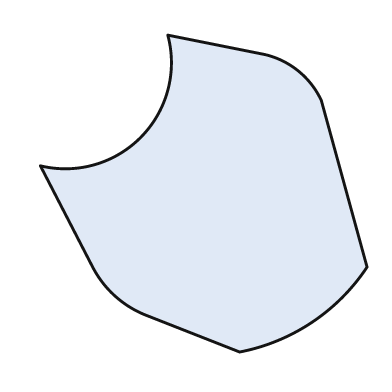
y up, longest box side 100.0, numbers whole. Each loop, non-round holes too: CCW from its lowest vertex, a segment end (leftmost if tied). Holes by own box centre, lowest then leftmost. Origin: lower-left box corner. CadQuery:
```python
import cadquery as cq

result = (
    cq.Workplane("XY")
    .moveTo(61.0, 0.0)
    .threePointArc((83.0, 9.0), (100.0, 26.0))
    .lineTo(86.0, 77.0)
    .threePointArc((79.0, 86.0), (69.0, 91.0))
    .lineTo(39.0, 97.0)
    .threePointArc((31.0, 66.0), (0.0, 57.0))
    .lineTo(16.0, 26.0)
    .threePointArc((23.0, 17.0), (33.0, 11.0))
    .close()
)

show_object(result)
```